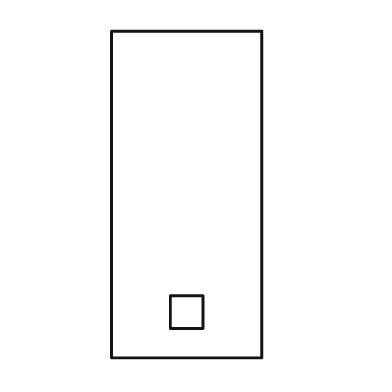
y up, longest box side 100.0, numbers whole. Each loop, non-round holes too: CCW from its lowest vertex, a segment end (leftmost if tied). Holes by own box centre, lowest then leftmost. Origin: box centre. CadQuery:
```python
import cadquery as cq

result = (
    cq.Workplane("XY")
    .moveTo(-23.0, -50.0)
    .lineTo(23.0, -50.0)
    .lineTo(23.0, 50.0)
    .lineTo(-23.0, 50.0)
    .close()
    .moveTo(-5.0, -41.0)
    .lineTo(5.0, -41.0)
    .lineTo(5.0, -31.0)
    .lineTo(-5.0, -31.0)
    .close()
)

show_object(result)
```